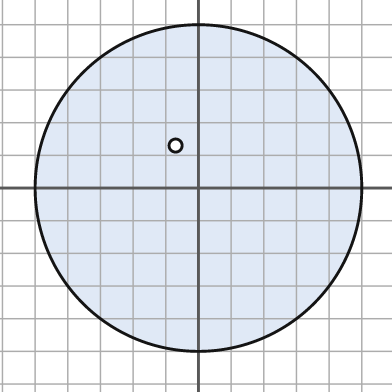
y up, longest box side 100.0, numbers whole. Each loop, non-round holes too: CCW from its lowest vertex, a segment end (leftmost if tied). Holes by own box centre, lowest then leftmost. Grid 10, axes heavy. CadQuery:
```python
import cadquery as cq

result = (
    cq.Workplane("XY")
    .moveTo(0.0, 0.0)
    .circle(50.0)
    .moveTo(-7.0, 13.0)
    .circle(2.0)
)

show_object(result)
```